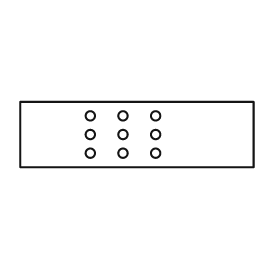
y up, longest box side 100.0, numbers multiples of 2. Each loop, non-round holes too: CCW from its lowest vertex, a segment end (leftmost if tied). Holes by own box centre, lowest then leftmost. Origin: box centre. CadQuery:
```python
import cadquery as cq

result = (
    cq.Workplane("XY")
    .moveTo(-50.0, -14.0)
    .lineTo(50.0, -14.0)
    .lineTo(50.0, 14.0)
    .lineTo(-50.0, 14.0)
    .close()
    .moveTo(-20.0, -8.0)
    .circle(2.0)
    .moveTo(-6.0, -8.0)
    .circle(2.0)
    .moveTo(8.0, -8.0)
    .circle(2.0)
    .moveTo(-20.0, 0.0)
    .circle(2.0)
    .moveTo(-6.0, 0.0)
    .circle(2.0)
    .moveTo(8.0, 0.0)
    .circle(2.0)
    .moveTo(-20.0, 8.0)
    .circle(2.0)
    .moveTo(-6.0, 8.0)
    .circle(2.0)
    .moveTo(8.0, 8.0)
    .circle(2.0)
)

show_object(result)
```